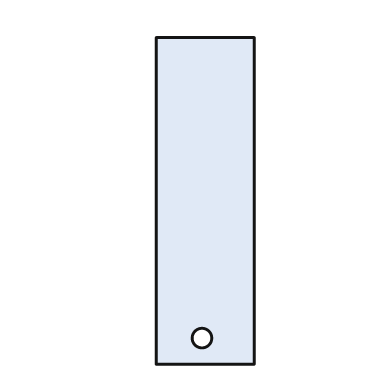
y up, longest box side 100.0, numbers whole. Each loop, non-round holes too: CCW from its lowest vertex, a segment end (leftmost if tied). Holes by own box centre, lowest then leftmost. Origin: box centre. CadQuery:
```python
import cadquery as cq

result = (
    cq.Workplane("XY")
    .moveTo(-15.0, -50.0)
    .lineTo(15.0, -50.0)
    .lineTo(15.0, 50.0)
    .lineTo(-15.0, 50.0)
    .close()
    .moveTo(-1.0, -42.0)
    .circle(3.0)
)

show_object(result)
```